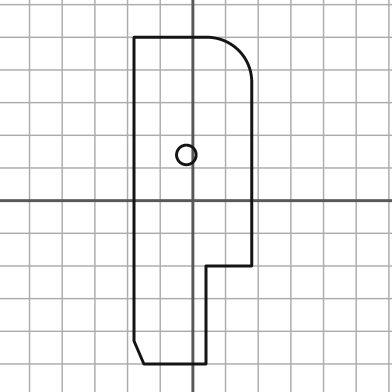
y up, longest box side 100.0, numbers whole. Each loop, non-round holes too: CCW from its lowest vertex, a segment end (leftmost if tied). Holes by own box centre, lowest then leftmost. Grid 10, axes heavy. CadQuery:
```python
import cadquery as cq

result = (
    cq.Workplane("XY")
    .moveTo(-15.0, -50.0)
    .lineTo(4.0, -50.0)
    .lineTo(4.0, -20.0)
    .lineTo(18.0, -20.0)
    .lineTo(18.0, 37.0)
    .threePointArc((14.0, 46.0), (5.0, 50.0))
    .lineTo(-18.0, 50.0)
    .lineTo(-18.0, -43.0)
    .close()
    .moveTo(-2.0, 14.0)
    .circle(3.0)
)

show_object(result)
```